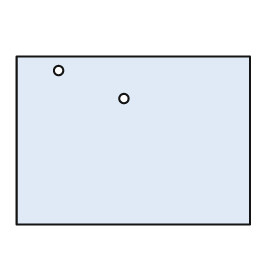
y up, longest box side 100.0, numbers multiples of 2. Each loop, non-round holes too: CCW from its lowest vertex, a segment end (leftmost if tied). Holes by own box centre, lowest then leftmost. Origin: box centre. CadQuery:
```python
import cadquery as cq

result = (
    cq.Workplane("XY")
    .moveTo(-50.0, -36.0)
    .lineTo(50.0, -36.0)
    .lineTo(50.0, 36.0)
    .lineTo(-50.0, 36.0)
    .close()
    .moveTo(-4.0, 18.0)
    .circle(2.0)
    .moveTo(-32.0, 30.0)
    .circle(2.0)
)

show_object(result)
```